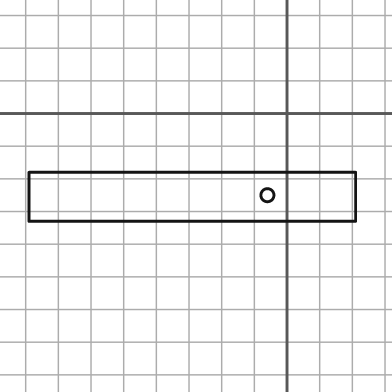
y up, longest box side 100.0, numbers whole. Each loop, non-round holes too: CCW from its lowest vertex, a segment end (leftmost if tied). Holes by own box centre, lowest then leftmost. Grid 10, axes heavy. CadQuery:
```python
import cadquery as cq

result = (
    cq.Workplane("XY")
    .moveTo(-79.0, -33.0)
    .lineTo(21.0, -33.0)
    .lineTo(21.0, -18.0)
    .lineTo(-79.0, -18.0)
    .close()
    .moveTo(-6.0, -25.0)
    .circle(2.0)
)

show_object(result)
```